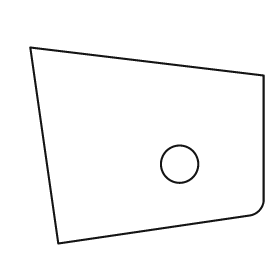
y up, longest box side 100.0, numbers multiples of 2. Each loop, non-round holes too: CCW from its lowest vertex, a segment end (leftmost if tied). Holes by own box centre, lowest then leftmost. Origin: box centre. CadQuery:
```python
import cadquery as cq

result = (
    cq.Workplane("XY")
    .moveTo(-38.0, -42.0)
    .lineTo(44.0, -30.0)
    .threePointArc((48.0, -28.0), (50.0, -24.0))
    .lineTo(50.0, 30.0)
    .lineTo(-50.0, 42.0)
    .close()
    .moveTo(14.0, -8.0)
    .circle(8.0)
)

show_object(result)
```